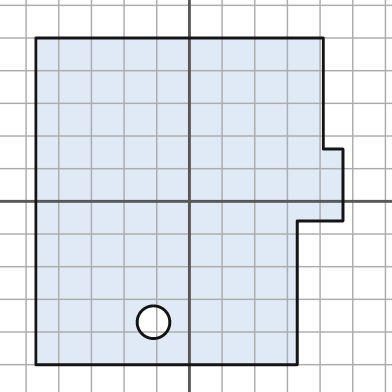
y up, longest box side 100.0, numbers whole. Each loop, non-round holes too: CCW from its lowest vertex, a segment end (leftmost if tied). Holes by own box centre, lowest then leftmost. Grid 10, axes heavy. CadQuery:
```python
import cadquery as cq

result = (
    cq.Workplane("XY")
    .moveTo(-47.0, -50.0)
    .lineTo(33.0, -50.0)
    .lineTo(33.0, -6.0)
    .lineTo(47.0, -6.0)
    .lineTo(47.0, 16.0)
    .lineTo(41.0, 16.0)
    .lineTo(41.0, 50.0)
    .lineTo(-47.0, 50.0)
    .close()
    .moveTo(-11.0, -37.0)
    .circle(5.0)
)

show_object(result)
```